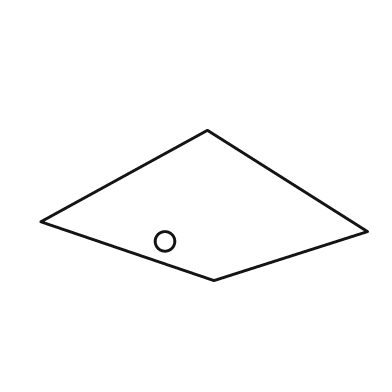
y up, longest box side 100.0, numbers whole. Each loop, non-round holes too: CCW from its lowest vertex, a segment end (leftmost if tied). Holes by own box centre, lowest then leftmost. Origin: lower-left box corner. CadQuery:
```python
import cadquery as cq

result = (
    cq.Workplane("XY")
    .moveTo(53.0, 0.0)
    .lineTo(100.0, 15.0)
    .lineTo(51.0, 46.0)
    .lineTo(0.0, 18.0)
    .close()
    .moveTo(38.0, 12.0)
    .circle(3.0)
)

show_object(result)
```